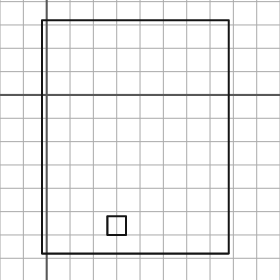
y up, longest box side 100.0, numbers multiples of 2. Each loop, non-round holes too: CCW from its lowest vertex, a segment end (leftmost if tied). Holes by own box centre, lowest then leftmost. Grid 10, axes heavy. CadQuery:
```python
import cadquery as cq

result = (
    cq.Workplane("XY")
    .moveTo(-2.0, -68.0)
    .lineTo(78.0, -68.0)
    .lineTo(78.0, 32.0)
    .lineTo(-2.0, 32.0)
    .close()
    .moveTo(26.0, -60.0)
    .lineTo(34.0, -60.0)
    .lineTo(34.0, -52.0)
    .lineTo(26.0, -52.0)
    .close()
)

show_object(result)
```